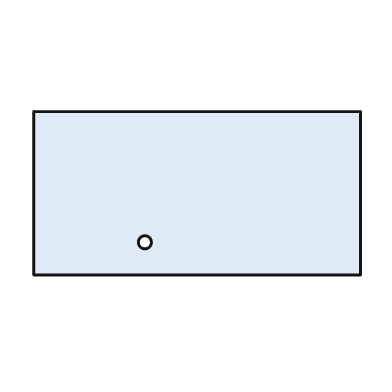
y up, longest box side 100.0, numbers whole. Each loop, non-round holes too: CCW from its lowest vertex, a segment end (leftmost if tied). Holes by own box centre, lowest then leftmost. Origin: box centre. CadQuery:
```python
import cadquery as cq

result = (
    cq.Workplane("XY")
    .moveTo(-50.0, -25.0)
    .lineTo(50.0, -25.0)
    .lineTo(50.0, 25.0)
    .lineTo(-50.0, 25.0)
    .close()
    .moveTo(-16.0, -15.0)
    .circle(2.0)
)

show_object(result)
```